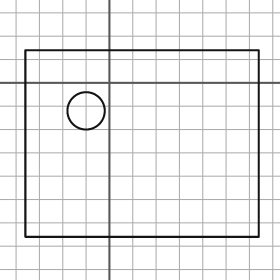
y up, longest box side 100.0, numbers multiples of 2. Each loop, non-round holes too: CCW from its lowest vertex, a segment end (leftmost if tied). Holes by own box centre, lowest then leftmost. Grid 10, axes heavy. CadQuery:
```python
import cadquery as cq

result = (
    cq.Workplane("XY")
    .moveTo(-36.0, -66.0)
    .lineTo(64.0, -66.0)
    .lineTo(64.0, 14.0)
    .lineTo(-36.0, 14.0)
    .close()
    .moveTo(-10.0, -12.0)
    .circle(8.0)
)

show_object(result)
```